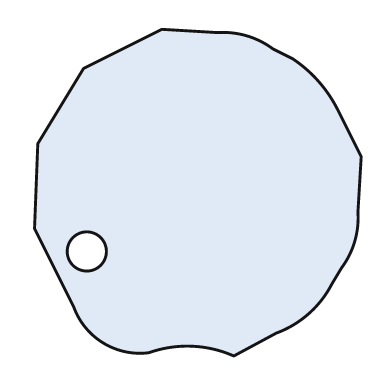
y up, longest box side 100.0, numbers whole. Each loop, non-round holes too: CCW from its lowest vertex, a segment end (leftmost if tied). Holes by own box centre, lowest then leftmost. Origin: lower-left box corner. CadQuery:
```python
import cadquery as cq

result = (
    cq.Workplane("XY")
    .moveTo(61.0, 0.0)
    .lineTo(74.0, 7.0)
    .threePointArc((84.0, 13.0), (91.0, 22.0))
    .lineTo(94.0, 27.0)
    .threePointArc((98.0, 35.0), (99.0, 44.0))
    .lineTo(100.0, 61.0)
    .lineTo(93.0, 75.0)
    .threePointArc((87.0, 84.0), (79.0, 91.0))
    .lineTo(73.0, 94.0)
    .threePointArc((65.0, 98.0), (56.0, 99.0))
    .lineTo(39.0, 100.0)
    .lineTo(15.0, 88.0)
    .lineTo(1.0, 65.0)
    .lineTo(0.0, 39.0)
    .lineTo(12.0, 15.0)
    .threePointArc((21.0, 4.0), (35.0, 1.0))
    .threePointArc((48.0, 3.0), (61.0, 0.0))
    .close()
    .moveTo(16.0, 32.0)
    .circle(6.0)
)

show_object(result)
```